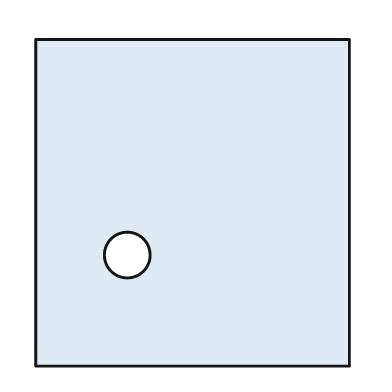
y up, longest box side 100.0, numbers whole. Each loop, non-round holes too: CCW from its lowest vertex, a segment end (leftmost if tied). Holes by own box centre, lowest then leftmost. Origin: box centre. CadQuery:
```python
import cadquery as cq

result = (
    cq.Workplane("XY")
    .moveTo(-48.0, -50.0)
    .lineTo(48.0, -50.0)
    .lineTo(48.0, 50.0)
    .lineTo(-48.0, 50.0)
    .close()
    .moveTo(-20.0, -16.0)
    .circle(7.0)
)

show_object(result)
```